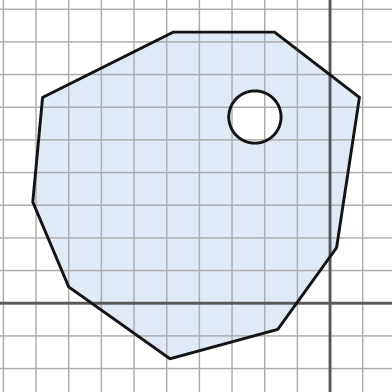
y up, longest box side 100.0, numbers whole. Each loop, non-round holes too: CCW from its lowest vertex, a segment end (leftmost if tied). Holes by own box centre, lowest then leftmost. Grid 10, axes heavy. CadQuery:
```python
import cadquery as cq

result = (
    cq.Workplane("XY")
    .moveTo(-49.0, -17.0)
    .lineTo(-16.0, -8.0)
    .lineTo(2.0, 17.0)
    .lineTo(9.0, 63.0)
    .lineTo(-17.0, 83.0)
    .lineTo(-48.0, 83.0)
    .lineTo(-88.0, 63.0)
    .lineTo(-91.0, 31.0)
    .lineTo(-80.0, 5.0)
    .close()
    .moveTo(-23.0, 57.0)
    .circle(8.0)
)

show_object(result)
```